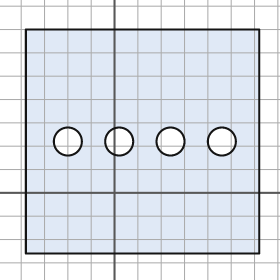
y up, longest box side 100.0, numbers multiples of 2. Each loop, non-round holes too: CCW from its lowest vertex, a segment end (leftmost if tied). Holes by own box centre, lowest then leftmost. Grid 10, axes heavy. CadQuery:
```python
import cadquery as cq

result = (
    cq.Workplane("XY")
    .moveTo(-38.0, -26.0)
    .lineTo(62.0, -26.0)
    .lineTo(62.0, 70.0)
    .lineTo(-38.0, 70.0)
    .close()
    .moveTo(-20.0, 22.0)
    .circle(6.0)
    .moveTo(2.0, 22.0)
    .circle(6.0)
    .moveTo(24.0, 22.0)
    .circle(6.0)
    .moveTo(46.0, 22.0)
    .circle(6.0)
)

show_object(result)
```